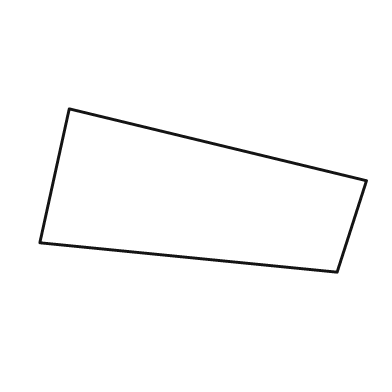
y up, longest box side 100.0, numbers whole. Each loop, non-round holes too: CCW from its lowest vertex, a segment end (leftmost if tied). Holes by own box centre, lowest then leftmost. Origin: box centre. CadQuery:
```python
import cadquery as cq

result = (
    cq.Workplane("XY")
    .moveTo(41.0, -25.0)
    .lineTo(50.0, 3.0)
    .lineTo(-41.0, 25.0)
    .lineTo(-50.0, -16.0)
    .close()
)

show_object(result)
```